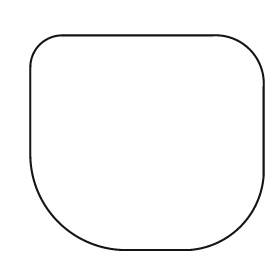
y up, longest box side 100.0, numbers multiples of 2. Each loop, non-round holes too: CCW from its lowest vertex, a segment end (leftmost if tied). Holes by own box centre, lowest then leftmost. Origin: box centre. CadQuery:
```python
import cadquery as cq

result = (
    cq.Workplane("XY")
    .moveTo(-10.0, -46.0)
    .lineTo(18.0, -46.0)
    .threePointArc((40.0, -36.0), (50.0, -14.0))
    .lineTo(50.0, 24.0)
    .threePointArc((44.0, 40.0), (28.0, 46.0))
    .lineTo(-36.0, 46.0)
    .threePointArc((-46.0, 42.0), (-50.0, 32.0))
    .lineTo(-50.0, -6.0)
    .threePointArc((-38.0, -34.0), (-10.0, -46.0))
    .close()
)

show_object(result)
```